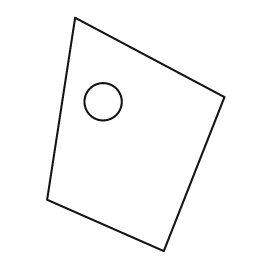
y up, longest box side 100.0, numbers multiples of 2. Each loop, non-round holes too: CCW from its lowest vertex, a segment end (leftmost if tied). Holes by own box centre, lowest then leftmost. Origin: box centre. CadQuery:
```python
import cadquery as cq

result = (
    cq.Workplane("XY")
    .moveTo(12.0, -50.0)
    .lineTo(38.0, 16.0)
    .lineTo(-26.0, 50.0)
    .lineTo(-38.0, -28.0)
    .close()
    .moveTo(-14.0, 14.0)
    .circle(8.0)
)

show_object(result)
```